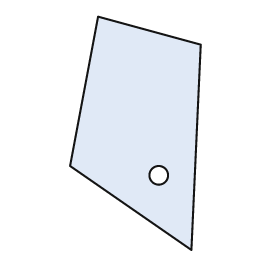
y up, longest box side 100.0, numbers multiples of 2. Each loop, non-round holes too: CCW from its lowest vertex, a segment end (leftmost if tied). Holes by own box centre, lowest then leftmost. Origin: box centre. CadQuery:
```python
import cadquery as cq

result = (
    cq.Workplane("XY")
    .moveTo(24.0, -50.0)
    .lineTo(28.0, 38.0)
    .lineTo(-16.0, 50.0)
    .lineTo(-28.0, -14.0)
    .close()
    .moveTo(10.0, -18.0)
    .circle(4.0)
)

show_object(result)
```